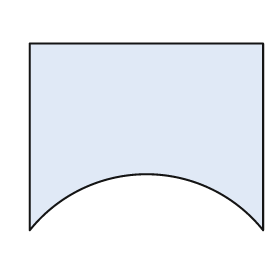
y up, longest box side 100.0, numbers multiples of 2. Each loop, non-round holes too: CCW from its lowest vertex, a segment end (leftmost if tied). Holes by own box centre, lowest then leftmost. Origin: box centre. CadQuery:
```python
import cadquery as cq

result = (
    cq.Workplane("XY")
    .moveTo(-50.0, -40.0)
    .threePointArc((0.0, -16.0), (50.0, -40.0))
    .lineTo(50.0, 40.0)
    .lineTo(-50.0, 40.0)
    .close()
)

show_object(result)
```